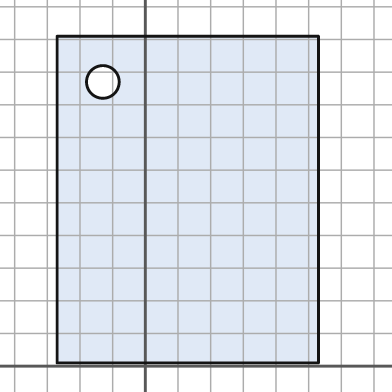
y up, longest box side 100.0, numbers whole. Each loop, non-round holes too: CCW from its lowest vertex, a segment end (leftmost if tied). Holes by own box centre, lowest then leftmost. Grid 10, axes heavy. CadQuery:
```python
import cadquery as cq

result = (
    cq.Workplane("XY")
    .moveTo(-27.0, 1.0)
    .lineTo(53.0, 1.0)
    .lineTo(53.0, 101.0)
    .lineTo(-27.0, 101.0)
    .close()
    .moveTo(-13.0, 87.0)
    .circle(5.0)
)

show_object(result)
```